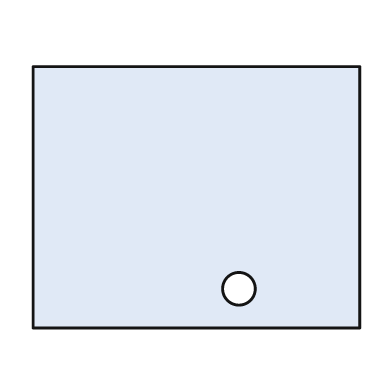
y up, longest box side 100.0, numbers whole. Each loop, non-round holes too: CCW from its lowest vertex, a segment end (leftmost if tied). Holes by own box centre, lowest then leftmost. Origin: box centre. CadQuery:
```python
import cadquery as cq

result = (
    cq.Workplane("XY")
    .moveTo(-50.0, -40.0)
    .lineTo(50.0, -40.0)
    .lineTo(50.0, 40.0)
    .lineTo(-50.0, 40.0)
    .close()
    .moveTo(13.0, -28.0)
    .circle(5.0)
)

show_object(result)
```